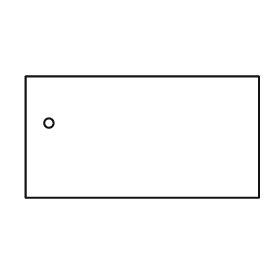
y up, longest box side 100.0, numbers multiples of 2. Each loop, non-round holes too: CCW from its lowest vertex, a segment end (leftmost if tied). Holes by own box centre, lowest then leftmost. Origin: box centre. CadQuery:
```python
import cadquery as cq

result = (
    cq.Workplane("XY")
    .moveTo(-50.0, -26.0)
    .lineTo(50.0, -26.0)
    .lineTo(50.0, 26.0)
    .lineTo(-50.0, 26.0)
    .close()
    .moveTo(-40.0, 6.0)
    .circle(2.0)
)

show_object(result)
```